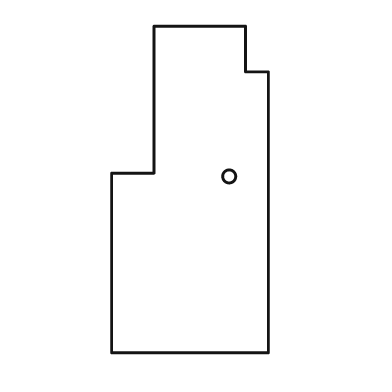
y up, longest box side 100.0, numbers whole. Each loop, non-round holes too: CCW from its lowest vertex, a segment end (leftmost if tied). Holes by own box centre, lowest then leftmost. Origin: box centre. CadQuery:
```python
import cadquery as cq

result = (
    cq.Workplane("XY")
    .moveTo(-24.0, -50.0)
    .lineTo(24.0, -50.0)
    .lineTo(24.0, 36.0)
    .lineTo(17.0, 36.0)
    .lineTo(17.0, 50.0)
    .lineTo(-11.0, 50.0)
    .lineTo(-11.0, 5.0)
    .lineTo(-24.0, 5.0)
    .close()
    .moveTo(12.0, 4.0)
    .circle(2.0)
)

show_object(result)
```